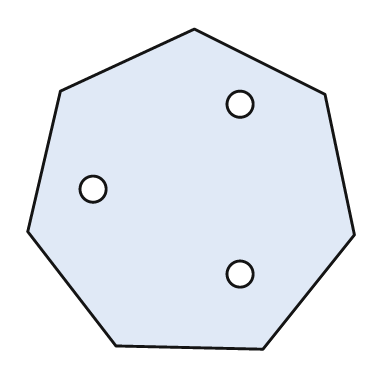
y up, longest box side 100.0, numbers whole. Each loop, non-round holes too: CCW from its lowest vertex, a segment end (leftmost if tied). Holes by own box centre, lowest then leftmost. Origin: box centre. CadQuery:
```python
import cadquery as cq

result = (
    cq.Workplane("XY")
    .moveTo(22.0, -49.0)
    .lineTo(50.0, -14.0)
    .lineTo(41.0, 29.0)
    .lineTo(1.0, 49.0)
    .lineTo(-40.0, 30.0)
    .lineTo(-50.0, -13.0)
    .lineTo(-23.0, -48.0)
    .close()
    .moveTo(15.0, -26.0)
    .circle(4.0)
    .moveTo(-30.0, 0.0)
    .circle(4.0)
    .moveTo(15.0, 26.0)
    .circle(4.0)
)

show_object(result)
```